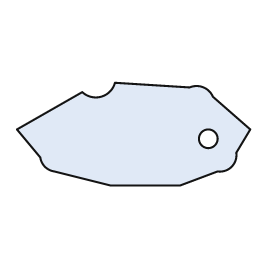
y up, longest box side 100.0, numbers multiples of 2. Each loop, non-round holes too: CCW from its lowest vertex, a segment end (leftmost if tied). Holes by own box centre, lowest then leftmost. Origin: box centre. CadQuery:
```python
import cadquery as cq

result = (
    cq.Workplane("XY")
    .moveTo(-10.0, -22.0)
    .lineTo(20.0, -22.0)
    .lineTo(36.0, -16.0)
    .threePointArc((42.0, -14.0), (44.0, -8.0))
    .lineTo(50.0, 2.0)
    .lineTo(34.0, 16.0)
    .threePointArc((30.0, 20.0), (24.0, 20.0))
    .lineTo(-8.0, 22.0)
    .threePointArc((-14.0, 16.0), (-22.0, 18.0))
    .lineTo(-50.0, 2.0)
    .lineTo(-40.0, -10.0)
    .threePointArc((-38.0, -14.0), (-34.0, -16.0))
    .close()
    .moveTo(32.0, -2.0)
    .circle(4.0)
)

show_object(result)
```